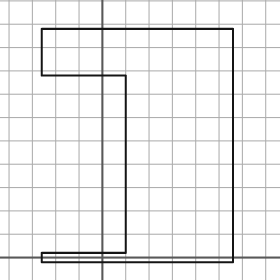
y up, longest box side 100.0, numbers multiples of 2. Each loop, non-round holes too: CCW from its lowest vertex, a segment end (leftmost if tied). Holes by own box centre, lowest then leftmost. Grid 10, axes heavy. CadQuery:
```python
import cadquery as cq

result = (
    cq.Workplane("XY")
    .moveTo(-26.0, -2.0)
    .lineTo(56.0, -2.0)
    .lineTo(56.0, 98.0)
    .lineTo(-26.0, 98.0)
    .lineTo(-26.0, 78.0)
    .lineTo(10.0, 78.0)
    .lineTo(10.0, 2.0)
    .lineTo(-26.0, 2.0)
    .close()
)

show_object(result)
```